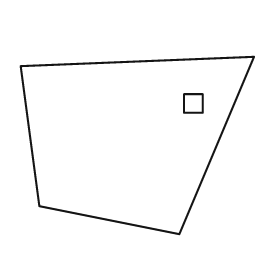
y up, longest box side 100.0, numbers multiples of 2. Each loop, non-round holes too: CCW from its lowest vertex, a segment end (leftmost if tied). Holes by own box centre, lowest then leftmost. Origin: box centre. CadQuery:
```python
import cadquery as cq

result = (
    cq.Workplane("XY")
    .moveTo(18.0, -38.0)
    .lineTo(50.0, 38.0)
    .lineTo(-50.0, 34.0)
    .lineTo(-42.0, -26.0)
    .close()
    .moveTo(20.0, 14.0)
    .lineTo(28.0, 14.0)
    .lineTo(28.0, 22.0)
    .lineTo(20.0, 22.0)
    .close()
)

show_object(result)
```